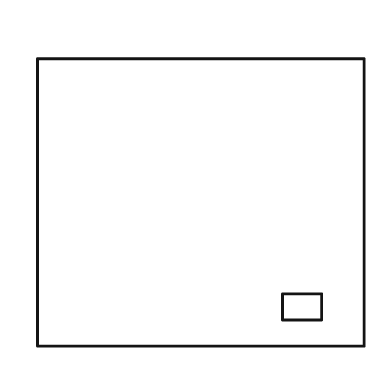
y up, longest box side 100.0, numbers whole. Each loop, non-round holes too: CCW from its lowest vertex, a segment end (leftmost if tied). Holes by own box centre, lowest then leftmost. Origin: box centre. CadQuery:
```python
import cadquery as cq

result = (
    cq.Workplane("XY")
    .moveTo(-50.0, -44.0)
    .lineTo(50.0, -44.0)
    .lineTo(50.0, 44.0)
    .lineTo(-50.0, 44.0)
    .close()
    .moveTo(25.0, -36.0)
    .lineTo(37.0, -36.0)
    .lineTo(37.0, -28.0)
    .lineTo(25.0, -28.0)
    .close()
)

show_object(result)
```